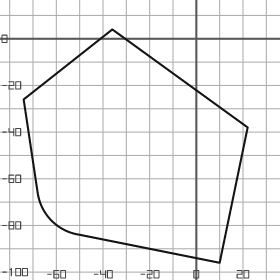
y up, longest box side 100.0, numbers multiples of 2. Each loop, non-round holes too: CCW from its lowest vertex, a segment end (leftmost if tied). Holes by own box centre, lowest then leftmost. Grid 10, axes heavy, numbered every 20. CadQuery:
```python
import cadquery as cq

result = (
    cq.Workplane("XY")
    .moveTo(10.0, -96.0)
    .lineTo(22.0, -38.0)
    .lineTo(-36.0, 4.0)
    .lineTo(-74.0, -26.0)
    .lineTo(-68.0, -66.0)
    .threePointArc((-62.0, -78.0), (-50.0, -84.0))
    .close()
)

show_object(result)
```